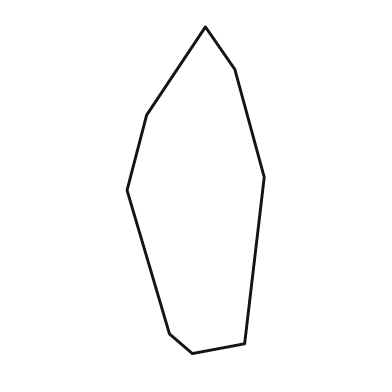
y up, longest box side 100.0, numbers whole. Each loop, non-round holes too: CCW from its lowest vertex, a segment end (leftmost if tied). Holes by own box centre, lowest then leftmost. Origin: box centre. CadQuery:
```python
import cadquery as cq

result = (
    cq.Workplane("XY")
    .moveTo(-1.0, -50.0)
    .lineTo(15.0, -47.0)
    .lineTo(21.0, 4.0)
    .lineTo(12.0, 37.0)
    .lineTo(3.0, 50.0)
    .lineTo(-15.0, 23.0)
    .lineTo(-21.0, 0.0)
    .lineTo(-8.0, -44.0)
    .close()
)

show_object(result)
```